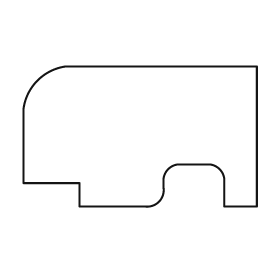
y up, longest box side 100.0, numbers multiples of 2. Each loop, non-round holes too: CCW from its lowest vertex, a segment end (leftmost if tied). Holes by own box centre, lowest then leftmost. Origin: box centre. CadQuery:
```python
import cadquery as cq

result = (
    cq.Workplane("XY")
    .moveTo(-26.0, -30.0)
    .lineTo(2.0, -30.0)
    .threePointArc((8.0, -28.0), (10.0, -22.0))
    .lineTo(10.0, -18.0)
    .threePointArc((12.0, -14.0), (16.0, -12.0))
    .lineTo(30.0, -12.0)
    .threePointArc((34.0, -14.0), (36.0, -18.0))
    .lineTo(36.0, -30.0)
    .lineTo(50.0, -30.0)
    .lineTo(50.0, 30.0)
    .lineTo(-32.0, 30.0)
    .threePointArc((-44.0, 24.0), (-50.0, 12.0))
    .lineTo(-50.0, -20.0)
    .lineTo(-26.0, -20.0)
    .close()
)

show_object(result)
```